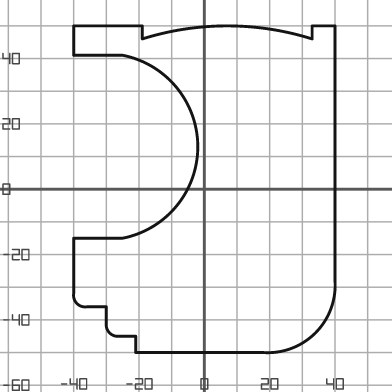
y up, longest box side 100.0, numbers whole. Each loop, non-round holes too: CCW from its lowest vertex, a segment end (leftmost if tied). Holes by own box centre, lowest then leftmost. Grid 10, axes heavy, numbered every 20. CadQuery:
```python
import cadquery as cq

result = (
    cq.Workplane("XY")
    .moveTo(-21.0, -50.0)
    .lineTo(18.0, -50.0)
    .threePointArc((34.0, -44.0), (40.0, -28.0))
    .lineTo(40.0, 50.0)
    .lineTo(33.0, 50.0)
    .lineTo(33.0, 46.0)
    .threePointArc((7.0, 50.0), (-19.0, 46.0))
    .lineTo(-19.0, 50.0)
    .lineTo(-40.0, 50.0)
    .lineTo(-40.0, 41.0)
    .lineTo(-25.0, 41.0)
    .threePointArc((-2.0, 13.0), (-25.0, -15.0))
    .lineTo(-40.0, -15.0)
    .lineTo(-40.0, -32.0)
    .threePointArc((-39.0, -35.0), (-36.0, -36.0))
    .lineTo(-30.0, -36.0)
    .lineTo(-30.0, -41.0)
    .threePointArc((-29.0, -44.0), (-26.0, -45.0))
    .lineTo(-21.0, -45.0)
    .close()
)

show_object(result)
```